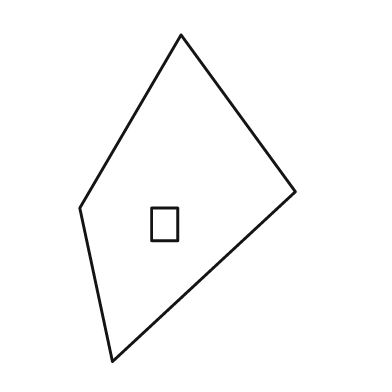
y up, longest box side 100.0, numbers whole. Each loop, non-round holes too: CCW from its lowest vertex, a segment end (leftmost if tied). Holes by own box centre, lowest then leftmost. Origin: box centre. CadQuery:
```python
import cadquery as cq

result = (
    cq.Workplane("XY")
    .moveTo(-23.0, -50.0)
    .lineTo(33.0, 2.0)
    .lineTo(-2.0, 50.0)
    .lineTo(-33.0, -3.0)
    .close()
    .moveTo(-11.0, -13.0)
    .lineTo(-3.0, -13.0)
    .lineTo(-3.0, -3.0)
    .lineTo(-11.0, -3.0)
    .close()
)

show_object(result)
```